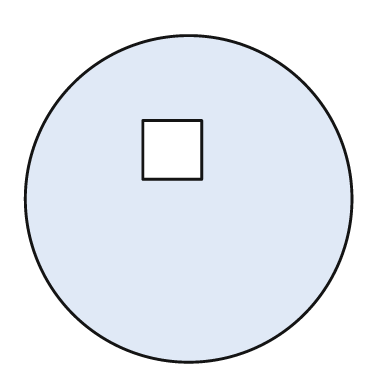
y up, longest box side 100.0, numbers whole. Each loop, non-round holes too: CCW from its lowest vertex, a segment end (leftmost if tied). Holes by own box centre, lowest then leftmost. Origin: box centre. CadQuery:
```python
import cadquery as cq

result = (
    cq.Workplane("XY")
    .moveTo(0.0, 0.0)
    .circle(50.0)
    .moveTo(-14.0, 6.0)
    .lineTo(4.0, 6.0)
    .lineTo(4.0, 24.0)
    .lineTo(-14.0, 24.0)
    .close()
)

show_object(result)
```